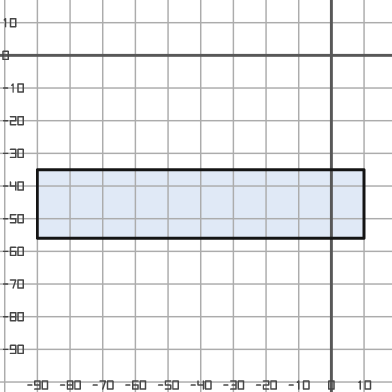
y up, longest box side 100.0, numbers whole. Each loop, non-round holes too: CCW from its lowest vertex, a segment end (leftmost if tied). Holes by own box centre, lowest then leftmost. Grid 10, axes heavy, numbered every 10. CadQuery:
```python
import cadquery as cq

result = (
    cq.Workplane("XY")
    .moveTo(-90.0, -56.0)
    .lineTo(10.0, -56.0)
    .lineTo(10.0, -35.0)
    .lineTo(-90.0, -35.0)
    .close()
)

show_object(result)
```